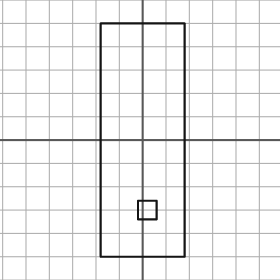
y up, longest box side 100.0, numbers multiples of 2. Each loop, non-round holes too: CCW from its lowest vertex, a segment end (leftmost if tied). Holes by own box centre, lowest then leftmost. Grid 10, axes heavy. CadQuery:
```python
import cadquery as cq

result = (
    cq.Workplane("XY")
    .moveTo(-18.0, -50.0)
    .lineTo(18.0, -50.0)
    .lineTo(18.0, 50.0)
    .lineTo(-18.0, 50.0)
    .close()
    .moveTo(-2.0, -34.0)
    .lineTo(6.0, -34.0)
    .lineTo(6.0, -26.0)
    .lineTo(-2.0, -26.0)
    .close()
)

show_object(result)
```